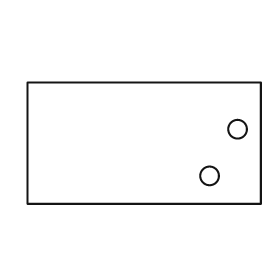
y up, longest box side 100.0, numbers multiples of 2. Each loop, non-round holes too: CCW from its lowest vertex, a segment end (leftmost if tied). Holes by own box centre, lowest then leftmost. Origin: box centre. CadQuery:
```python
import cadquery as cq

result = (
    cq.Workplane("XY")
    .moveTo(-50.0, -26.0)
    .lineTo(50.0, -26.0)
    .lineTo(50.0, 26.0)
    .lineTo(-50.0, 26.0)
    .close()
    .moveTo(28.0, -14.0)
    .circle(4.0)
    .moveTo(40.0, 6.0)
    .circle(4.0)
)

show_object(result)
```